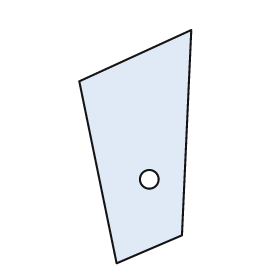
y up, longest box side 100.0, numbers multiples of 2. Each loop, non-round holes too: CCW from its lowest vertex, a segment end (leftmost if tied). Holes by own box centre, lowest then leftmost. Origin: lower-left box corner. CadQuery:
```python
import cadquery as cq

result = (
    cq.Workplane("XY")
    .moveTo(16.0, 0.0)
    .lineTo(44.0, 12.0)
    .lineTo(48.0, 100.0)
    .lineTo(0.0, 78.0)
    .close()
    .moveTo(30.0, 36.0)
    .circle(4.0)
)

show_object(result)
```